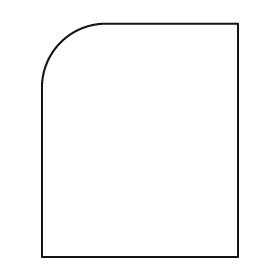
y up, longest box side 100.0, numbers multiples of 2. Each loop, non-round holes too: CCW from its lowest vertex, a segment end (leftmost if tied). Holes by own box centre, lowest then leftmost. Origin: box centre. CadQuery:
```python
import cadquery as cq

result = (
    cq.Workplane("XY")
    .moveTo(-42.0, -50.0)
    .lineTo(42.0, -50.0)
    .lineTo(42.0, 50.0)
    .lineTo(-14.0, 50.0)
    .threePointArc((-34.0, 42.0), (-42.0, 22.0))
    .close()
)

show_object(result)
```